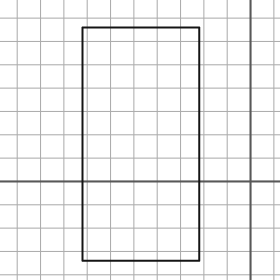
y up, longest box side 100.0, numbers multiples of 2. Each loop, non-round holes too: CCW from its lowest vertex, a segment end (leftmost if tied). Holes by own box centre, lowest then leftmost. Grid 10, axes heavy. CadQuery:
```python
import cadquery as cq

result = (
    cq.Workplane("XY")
    .moveTo(-72.0, -34.0)
    .lineTo(-22.0, -34.0)
    .lineTo(-22.0, 66.0)
    .lineTo(-72.0, 66.0)
    .close()
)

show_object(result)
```